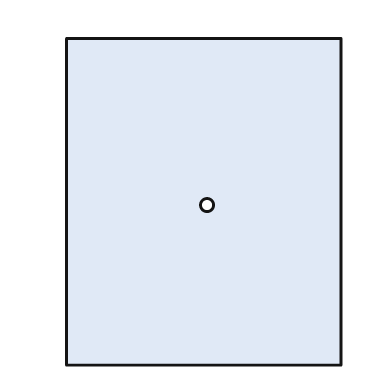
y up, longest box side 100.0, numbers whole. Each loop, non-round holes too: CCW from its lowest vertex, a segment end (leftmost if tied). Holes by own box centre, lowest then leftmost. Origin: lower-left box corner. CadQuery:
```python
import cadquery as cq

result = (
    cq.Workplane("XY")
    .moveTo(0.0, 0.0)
    .lineTo(84.0, 0.0)
    .lineTo(84.0, 100.0)
    .lineTo(0.0, 100.0)
    .close()
    .moveTo(43.0, 49.0)
    .circle(2.0)
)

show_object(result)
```